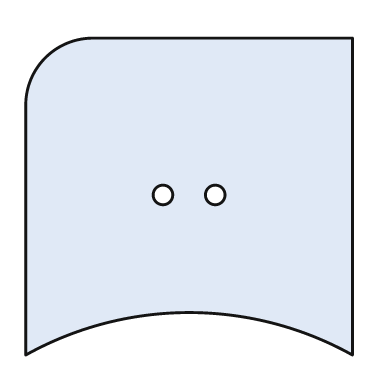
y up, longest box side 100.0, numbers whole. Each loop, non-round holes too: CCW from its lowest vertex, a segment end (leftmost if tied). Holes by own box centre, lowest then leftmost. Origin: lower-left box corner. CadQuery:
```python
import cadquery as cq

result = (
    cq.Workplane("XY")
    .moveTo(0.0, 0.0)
    .threePointArc((50.0, 13.0), (100.0, 0.0))
    .lineTo(100.0, 97.0)
    .lineTo(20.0, 97.0)
    .threePointArc((6.0, 91.0), (0.0, 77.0))
    .close()
    .moveTo(42.0, 49.0)
    .circle(3.0)
    .moveTo(58.0, 49.0)
    .circle(3.0)
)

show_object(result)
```